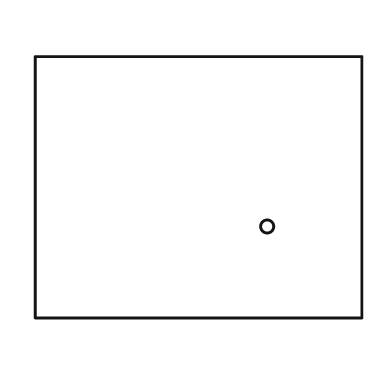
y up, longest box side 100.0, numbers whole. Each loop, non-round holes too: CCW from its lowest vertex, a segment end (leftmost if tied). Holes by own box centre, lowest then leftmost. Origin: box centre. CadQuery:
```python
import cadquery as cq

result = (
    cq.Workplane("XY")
    .moveTo(-50.0, -40.0)
    .lineTo(50.0, -40.0)
    .lineTo(50.0, 40.0)
    .lineTo(-50.0, 40.0)
    .close()
    .moveTo(21.0, -12.0)
    .circle(2.0)
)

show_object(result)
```